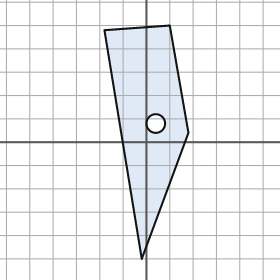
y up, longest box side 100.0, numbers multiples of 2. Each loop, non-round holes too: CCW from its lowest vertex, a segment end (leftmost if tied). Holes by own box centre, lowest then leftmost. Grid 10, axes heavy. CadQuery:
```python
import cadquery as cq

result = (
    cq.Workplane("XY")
    .moveTo(-2.0, -50.0)
    .lineTo(18.0, 4.0)
    .lineTo(10.0, 50.0)
    .lineTo(-18.0, 48.0)
    .close()
    .moveTo(4.0, 8.0)
    .circle(4.0)
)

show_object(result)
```